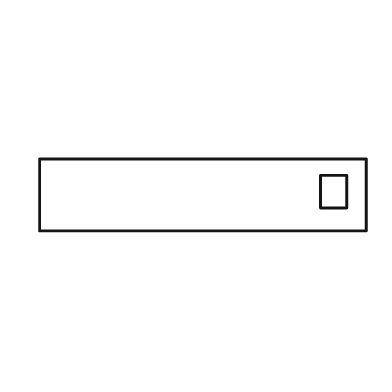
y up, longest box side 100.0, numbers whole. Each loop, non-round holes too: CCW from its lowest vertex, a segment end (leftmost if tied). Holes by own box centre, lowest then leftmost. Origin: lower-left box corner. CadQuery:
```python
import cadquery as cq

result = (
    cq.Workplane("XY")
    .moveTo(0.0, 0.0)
    .lineTo(100.0, 0.0)
    .lineTo(100.0, 22.0)
    .lineTo(0.0, 22.0)
    .close()
    .moveTo(86.0, 7.0)
    .lineTo(94.0, 7.0)
    .lineTo(94.0, 17.0)
    .lineTo(86.0, 17.0)
    .close()
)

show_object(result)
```